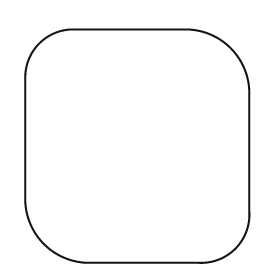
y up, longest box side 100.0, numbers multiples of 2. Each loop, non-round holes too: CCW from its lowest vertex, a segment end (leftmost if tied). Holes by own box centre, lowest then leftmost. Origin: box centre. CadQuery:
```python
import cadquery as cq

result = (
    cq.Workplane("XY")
    .moveTo(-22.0, -50.0)
    .lineTo(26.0, -50.0)
    .threePointArc((42.0, -44.0), (48.0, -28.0))
    .lineTo(48.0, 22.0)
    .threePointArc((40.0, 42.0), (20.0, 50.0))
    .lineTo(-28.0, 50.0)
    .threePointArc((-42.0, 44.0), (-48.0, 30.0))
    .lineTo(-48.0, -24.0)
    .threePointArc((-40.0, -42.0), (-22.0, -50.0))
    .close()
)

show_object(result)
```